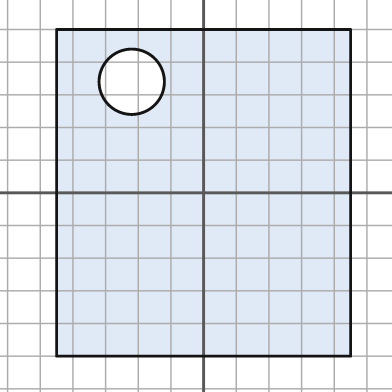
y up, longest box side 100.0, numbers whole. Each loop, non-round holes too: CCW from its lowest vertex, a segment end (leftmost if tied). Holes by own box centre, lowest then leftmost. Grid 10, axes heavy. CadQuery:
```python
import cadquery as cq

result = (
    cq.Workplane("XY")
    .moveTo(-45.0, -50.0)
    .lineTo(45.0, -50.0)
    .lineTo(45.0, 50.0)
    .lineTo(-45.0, 50.0)
    .close()
    .moveTo(-22.0, 34.0)
    .circle(10.0)
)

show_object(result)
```